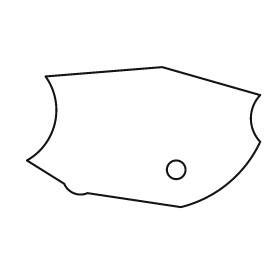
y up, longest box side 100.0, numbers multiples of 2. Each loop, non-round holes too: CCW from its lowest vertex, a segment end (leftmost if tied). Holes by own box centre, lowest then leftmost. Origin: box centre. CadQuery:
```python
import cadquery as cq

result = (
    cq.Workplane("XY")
    .moveTo(16.0, -30.0)
    .threePointArc((36.0, -20.0), (50.0, -2.0))
    .threePointArc((46.0, 8.0), (50.0, 18.0))
    .lineTo(8.0, 30.0)
    .lineTo(-42.0, 26.0)
    .threePointArc((-38.0, 6.0), (-50.0, -10.0))
    .lineTo(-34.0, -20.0)
    .threePointArc((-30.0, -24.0), (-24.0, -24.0))
    .close()
    .moveTo(14.0, -14.0)
    .circle(4.0)
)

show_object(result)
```